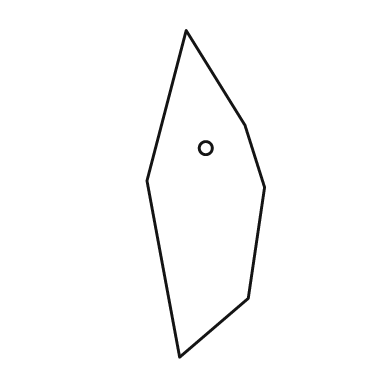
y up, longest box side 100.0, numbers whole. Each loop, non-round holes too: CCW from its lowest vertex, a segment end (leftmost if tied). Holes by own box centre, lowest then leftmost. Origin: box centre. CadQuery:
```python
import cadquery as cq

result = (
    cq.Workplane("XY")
    .moveTo(-8.0, -50.0)
    .lineTo(13.0, -32.0)
    .lineTo(18.0, 2.0)
    .lineTo(12.0, 21.0)
    .lineTo(-6.0, 50.0)
    .lineTo(-18.0, 4.0)
    .close()
    .moveTo(0.0, 14.0)
    .circle(2.0)
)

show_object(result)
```